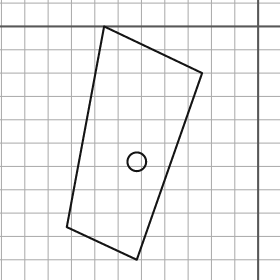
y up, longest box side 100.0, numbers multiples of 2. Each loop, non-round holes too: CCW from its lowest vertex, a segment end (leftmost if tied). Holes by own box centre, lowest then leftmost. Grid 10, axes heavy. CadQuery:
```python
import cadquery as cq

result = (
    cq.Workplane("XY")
    .moveTo(-52.0, -100.0)
    .lineTo(-24.0, -20.0)
    .lineTo(-66.0, 0.0)
    .lineTo(-82.0, -86.0)
    .close()
    .moveTo(-52.0, -58.0)
    .circle(4.0)
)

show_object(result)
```